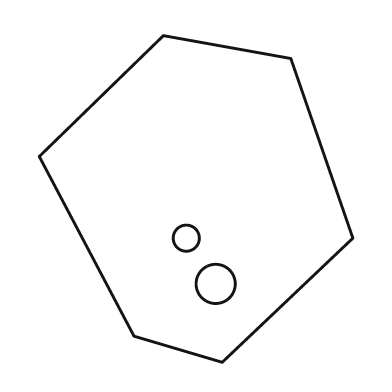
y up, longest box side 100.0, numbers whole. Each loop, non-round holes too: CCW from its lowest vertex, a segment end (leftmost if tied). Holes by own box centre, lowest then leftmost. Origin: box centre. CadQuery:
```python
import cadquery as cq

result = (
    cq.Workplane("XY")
    .moveTo(8.0, -50.0)
    .lineTo(48.0, -12.0)
    .lineTo(29.0, 43.0)
    .lineTo(-10.0, 50.0)
    .lineTo(-48.0, 13.0)
    .lineTo(-19.0, -42.0)
    .close()
    .moveTo(6.0, -26.0)
    .circle(6.0)
    .moveTo(-3.0, -12.0)
    .circle(4.0)
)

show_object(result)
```